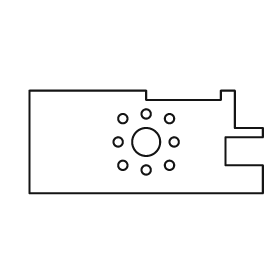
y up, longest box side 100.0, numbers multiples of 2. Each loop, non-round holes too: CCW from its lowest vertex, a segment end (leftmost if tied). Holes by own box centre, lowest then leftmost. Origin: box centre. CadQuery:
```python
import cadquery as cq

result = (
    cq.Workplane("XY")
    .moveTo(-50.0, -22.0)
    .lineTo(50.0, -22.0)
    .lineTo(50.0, -10.0)
    .lineTo(34.0, -10.0)
    .lineTo(34.0, 2.0)
    .lineTo(50.0, 2.0)
    .lineTo(50.0, 6.0)
    .lineTo(38.0, 6.0)
    .lineTo(38.0, 22.0)
    .lineTo(32.0, 22.0)
    .lineTo(32.0, 18.0)
    .lineTo(0.0, 18.0)
    .lineTo(0.0, 22.0)
    .lineTo(-50.0, 22.0)
    .close()
    .moveTo(0.0, -12.0)
    .circle(2.0)
    .moveTo(-10.0, -10.0)
    .circle(2.0)
    .moveTo(10.0, -10.0)
    .circle(2.0)
    .moveTo(-12.0, 0.0)
    .circle(2.0)
    .moveTo(0.0, 0.0)
    .circle(6.0)
    .moveTo(12.0, 0.0)
    .circle(2.0)
    .moveTo(-10.0, 10.0)
    .circle(2.0)
    .moveTo(10.0, 10.0)
    .circle(2.0)
    .moveTo(0.0, 12.0)
    .circle(2.0)
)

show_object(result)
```